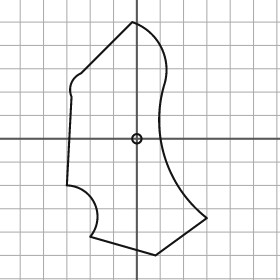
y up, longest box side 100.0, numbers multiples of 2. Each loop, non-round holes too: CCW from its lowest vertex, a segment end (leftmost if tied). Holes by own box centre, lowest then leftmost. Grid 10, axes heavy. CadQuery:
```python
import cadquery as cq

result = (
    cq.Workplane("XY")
    .moveTo(8.0, -50.0)
    .lineTo(30.0, -34.0)
    .threePointArc((12.0, -8.0), (12.0, 24.0))
    .threePointArc((10.0, 40.0), (-2.0, 50.0))
    .lineTo(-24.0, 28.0)
    .threePointArc((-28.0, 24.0), (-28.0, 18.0))
    .lineTo(-30.0, -20.0)
    .threePointArc((-18.0, -28.0), (-20.0, -42.0))
    .close()
    .moveTo(0.0, 0.0)
    .circle(2.0)
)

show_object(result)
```